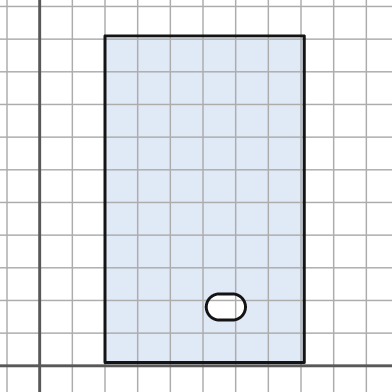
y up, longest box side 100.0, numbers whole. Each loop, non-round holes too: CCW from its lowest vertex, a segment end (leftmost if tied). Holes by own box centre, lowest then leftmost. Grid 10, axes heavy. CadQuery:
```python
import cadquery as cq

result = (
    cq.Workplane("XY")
    .moveTo(20.0, 1.0)
    .lineTo(81.0, 1.0)
    .lineTo(81.0, 101.0)
    .lineTo(20.0, 101.0)
    .close()
    .moveTo(55.0, 14.0)
    .lineTo(59.0, 14.0)
    .threePointArc((63.0, 18.0), (59.0, 22.0))
    .lineTo(55.0, 22.0)
    .threePointArc((51.0, 18.0), (55.0, 14.0))
    .close()
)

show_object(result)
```